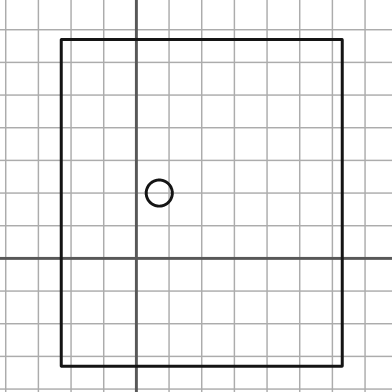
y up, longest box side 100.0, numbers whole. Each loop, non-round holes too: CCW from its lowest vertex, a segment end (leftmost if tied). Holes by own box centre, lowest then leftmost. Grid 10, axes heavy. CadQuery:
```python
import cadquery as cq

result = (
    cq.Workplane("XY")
    .moveTo(-23.0, -33.0)
    .lineTo(63.0, -33.0)
    .lineTo(63.0, 67.0)
    .lineTo(-23.0, 67.0)
    .close()
    .moveTo(7.0, 20.0)
    .circle(4.0)
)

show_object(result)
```